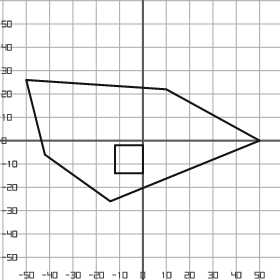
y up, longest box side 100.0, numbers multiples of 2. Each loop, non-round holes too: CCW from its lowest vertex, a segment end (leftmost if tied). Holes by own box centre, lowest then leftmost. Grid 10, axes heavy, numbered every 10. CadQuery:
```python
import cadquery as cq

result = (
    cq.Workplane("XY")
    .moveTo(-14.0, -26.0)
    .lineTo(50.0, 0.0)
    .lineTo(10.0, 22.0)
    .lineTo(-50.0, 26.0)
    .lineTo(-42.0, -6.0)
    .close()
    .moveTo(-12.0, -14.0)
    .lineTo(0.0, -14.0)
    .lineTo(0.0, -2.0)
    .lineTo(-12.0, -2.0)
    .close()
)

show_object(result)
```